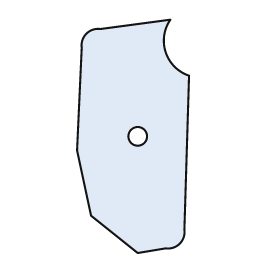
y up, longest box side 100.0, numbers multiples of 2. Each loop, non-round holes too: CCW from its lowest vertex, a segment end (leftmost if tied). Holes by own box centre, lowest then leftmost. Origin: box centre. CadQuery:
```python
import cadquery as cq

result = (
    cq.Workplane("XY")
    .moveTo(2.0, -50.0)
    .lineTo(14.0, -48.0)
    .threePointArc((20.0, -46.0), (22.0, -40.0))
    .lineTo(24.0, 26.0)
    .threePointArc((14.0, 36.0), (16.0, 50.0))
    .lineTo(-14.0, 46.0)
    .threePointArc((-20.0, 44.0), (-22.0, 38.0))
    .lineTo(-24.0, -6.0)
    .lineTo(-18.0, -34.0)
    .close()
    .moveTo(2.0, 0.0)
    .circle(4.0)
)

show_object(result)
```